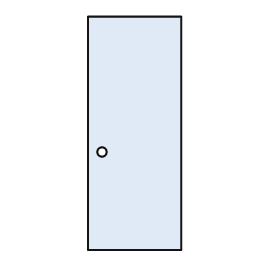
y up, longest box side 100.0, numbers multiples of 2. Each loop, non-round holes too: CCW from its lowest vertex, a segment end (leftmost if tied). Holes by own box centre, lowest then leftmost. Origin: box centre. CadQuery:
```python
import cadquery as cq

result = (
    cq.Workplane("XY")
    .moveTo(-20.0, -50.0)
    .lineTo(20.0, -50.0)
    .lineTo(20.0, 50.0)
    .lineTo(-20.0, 50.0)
    .close()
    .moveTo(-14.0, -8.0)
    .circle(2.0)
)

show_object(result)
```